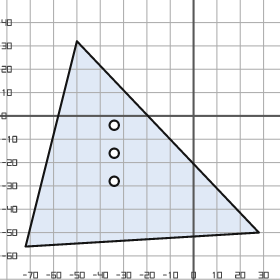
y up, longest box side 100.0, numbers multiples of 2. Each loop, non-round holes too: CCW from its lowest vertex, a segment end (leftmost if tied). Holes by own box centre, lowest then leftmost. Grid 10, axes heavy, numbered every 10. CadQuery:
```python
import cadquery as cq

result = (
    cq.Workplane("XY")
    .moveTo(-72.0, -56.0)
    .lineTo(28.0, -50.0)
    .lineTo(-50.0, 32.0)
    .close()
    .moveTo(-34.0, -28.0)
    .circle(2.0)
    .moveTo(-34.0, -16.0)
    .circle(2.0)
    .moveTo(-34.0, -4.0)
    .circle(2.0)
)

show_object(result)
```